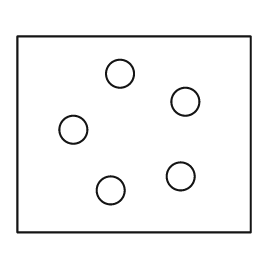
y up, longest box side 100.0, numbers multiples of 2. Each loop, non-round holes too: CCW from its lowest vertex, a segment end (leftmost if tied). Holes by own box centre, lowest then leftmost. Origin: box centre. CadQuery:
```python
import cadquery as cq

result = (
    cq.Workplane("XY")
    .moveTo(-50.0, -42.0)
    .lineTo(50.0, -42.0)
    .lineTo(50.0, 42.0)
    .lineTo(-50.0, 42.0)
    .close()
    .moveTo(-10.0, -24.0)
    .circle(6.0)
    .moveTo(20.0, -18.0)
    .circle(6.0)
    .moveTo(-26.0, 2.0)
    .circle(6.0)
    .moveTo(22.0, 14.0)
    .circle(6.0)
    .moveTo(-6.0, 26.0)
    .circle(6.0)
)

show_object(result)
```